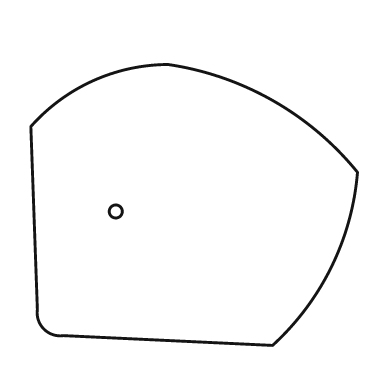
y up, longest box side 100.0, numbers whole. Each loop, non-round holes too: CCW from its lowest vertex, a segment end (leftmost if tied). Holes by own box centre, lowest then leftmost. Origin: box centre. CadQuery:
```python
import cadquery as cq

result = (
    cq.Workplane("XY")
    .moveTo(24.0, -43.0)
    .threePointArc((42.0, -19.0), (50.0, 10.0))
    .threePointArc((24.0, 32.0), (-8.0, 43.0))
    .threePointArc((-31.0, 38.0), (-50.0, 24.0))
    .lineTo(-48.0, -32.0)
    .threePointArc((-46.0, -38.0), (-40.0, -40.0))
    .close()
    .moveTo(-24.0, -2.0)
    .circle(2.0)
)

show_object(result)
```